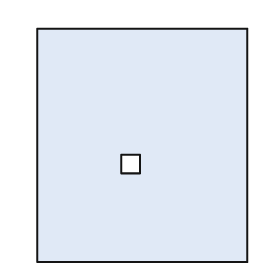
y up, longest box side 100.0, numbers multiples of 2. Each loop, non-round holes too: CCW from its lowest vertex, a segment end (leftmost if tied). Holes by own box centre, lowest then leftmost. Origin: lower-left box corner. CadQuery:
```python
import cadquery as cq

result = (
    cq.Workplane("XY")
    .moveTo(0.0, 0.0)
    .lineTo(90.0, 0.0)
    .lineTo(90.0, 100.0)
    .lineTo(0.0, 100.0)
    .close()
    .moveTo(36.0, 38.0)
    .lineTo(44.0, 38.0)
    .lineTo(44.0, 46.0)
    .lineTo(36.0, 46.0)
    .close()
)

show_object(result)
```